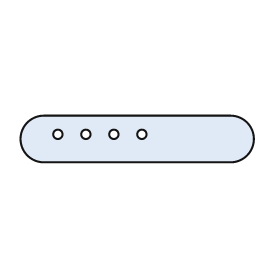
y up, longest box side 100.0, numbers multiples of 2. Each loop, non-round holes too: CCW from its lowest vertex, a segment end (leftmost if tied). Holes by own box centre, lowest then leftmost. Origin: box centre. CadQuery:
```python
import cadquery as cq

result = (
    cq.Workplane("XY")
    .moveTo(-40.0, -10.0)
    .lineTo(40.0, -10.0)
    .threePointArc((50.0, 0.0), (40.0, 10.0))
    .lineTo(-40.0, 10.0)
    .threePointArc((-50.0, 0.0), (-40.0, -10.0))
    .close()
    .moveTo(-34.0, 2.0)
    .circle(2.0)
    .moveTo(-22.0, 2.0)
    .circle(2.0)
    .moveTo(-10.0, 2.0)
    .circle(2.0)
    .moveTo(2.0, 2.0)
    .circle(2.0)
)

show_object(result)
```